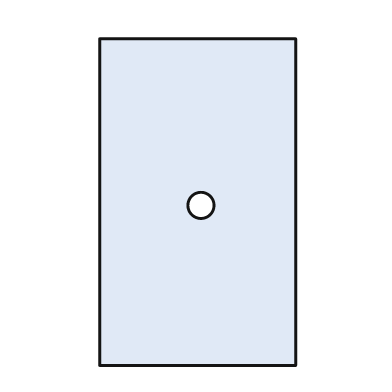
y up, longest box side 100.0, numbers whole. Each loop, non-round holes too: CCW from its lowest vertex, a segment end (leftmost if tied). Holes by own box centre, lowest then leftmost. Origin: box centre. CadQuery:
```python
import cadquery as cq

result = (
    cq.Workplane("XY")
    .moveTo(-30.0, -50.0)
    .lineTo(30.0, -50.0)
    .lineTo(30.0, 50.0)
    .lineTo(-30.0, 50.0)
    .close()
    .moveTo(1.0, -1.0)
    .circle(4.0)
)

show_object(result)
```